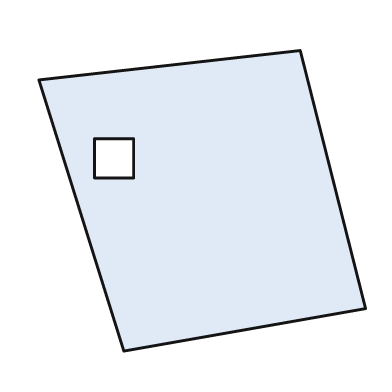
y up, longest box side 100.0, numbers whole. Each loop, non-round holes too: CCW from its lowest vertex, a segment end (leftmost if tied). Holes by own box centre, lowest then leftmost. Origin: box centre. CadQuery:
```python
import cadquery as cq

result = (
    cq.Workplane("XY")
    .moveTo(-24.0, -46.0)
    .lineTo(50.0, -33.0)
    .lineTo(30.0, 46.0)
    .lineTo(-50.0, 37.0)
    .close()
    .moveTo(-33.0, 7.0)
    .lineTo(-21.0, 7.0)
    .lineTo(-21.0, 19.0)
    .lineTo(-33.0, 19.0)
    .close()
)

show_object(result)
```